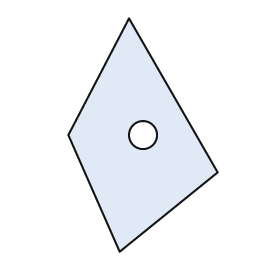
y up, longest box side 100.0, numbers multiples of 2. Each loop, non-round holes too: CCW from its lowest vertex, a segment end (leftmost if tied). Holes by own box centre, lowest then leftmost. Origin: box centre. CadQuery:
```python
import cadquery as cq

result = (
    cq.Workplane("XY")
    .moveTo(-10.0, -50.0)
    .lineTo(32.0, -16.0)
    .lineTo(-6.0, 50.0)
    .lineTo(-32.0, 0.0)
    .close()
    .moveTo(0.0, 0.0)
    .circle(6.0)
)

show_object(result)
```